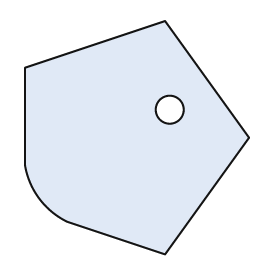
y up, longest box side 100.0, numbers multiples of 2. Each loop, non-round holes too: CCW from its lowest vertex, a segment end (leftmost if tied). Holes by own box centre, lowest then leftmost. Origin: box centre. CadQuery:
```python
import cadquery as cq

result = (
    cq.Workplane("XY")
    .moveTo(12.0, -50.0)
    .lineTo(48.0, 0.0)
    .lineTo(12.0, 50.0)
    .lineTo(-48.0, 30.0)
    .lineTo(-48.0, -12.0)
    .threePointArc((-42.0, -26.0), (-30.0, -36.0))
    .close()
    .moveTo(14.0, 12.0)
    .circle(6.0)
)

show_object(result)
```